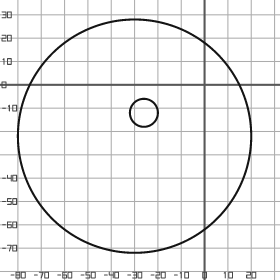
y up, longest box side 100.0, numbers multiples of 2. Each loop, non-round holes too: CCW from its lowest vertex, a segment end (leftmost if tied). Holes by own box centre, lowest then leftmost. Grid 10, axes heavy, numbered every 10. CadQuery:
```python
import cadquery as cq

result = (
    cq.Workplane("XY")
    .moveTo(-30.0, -22.0)
    .circle(50.0)
    .moveTo(-26.0, -12.0)
    .circle(6.0)
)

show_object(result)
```